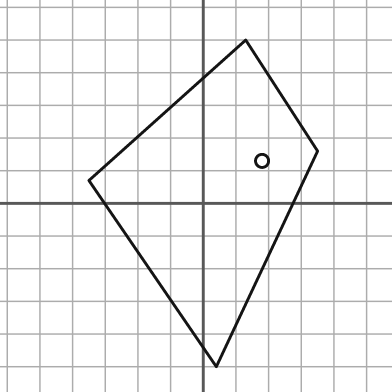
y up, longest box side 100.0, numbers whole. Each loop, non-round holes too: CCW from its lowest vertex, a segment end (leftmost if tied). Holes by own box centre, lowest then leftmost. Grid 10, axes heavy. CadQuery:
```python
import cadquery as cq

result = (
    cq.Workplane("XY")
    .moveTo(4.0, -50.0)
    .lineTo(35.0, 16.0)
    .lineTo(13.0, 50.0)
    .lineTo(-35.0, 7.0)
    .close()
    .moveTo(18.0, 13.0)
    .circle(2.0)
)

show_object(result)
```